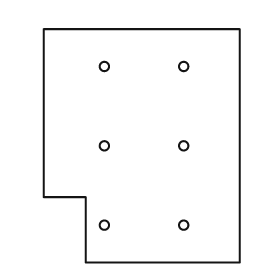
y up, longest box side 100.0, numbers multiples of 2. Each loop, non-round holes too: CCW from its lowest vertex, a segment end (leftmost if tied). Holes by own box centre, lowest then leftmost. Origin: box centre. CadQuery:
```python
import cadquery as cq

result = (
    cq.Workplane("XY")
    .moveTo(-24.0, -50.0)
    .lineTo(42.0, -50.0)
    .lineTo(42.0, 50.0)
    .lineTo(-42.0, 50.0)
    .lineTo(-42.0, -22.0)
    .lineTo(-24.0, -22.0)
    .close()
    .moveTo(-16.0, -34.0)
    .circle(2.0)
    .moveTo(18.0, -34.0)
    .circle(2.0)
    .moveTo(-16.0, 0.0)
    .circle(2.0)
    .moveTo(18.0, 0.0)
    .circle(2.0)
    .moveTo(-16.0, 34.0)
    .circle(2.0)
    .moveTo(18.0, 34.0)
    .circle(2.0)
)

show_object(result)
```